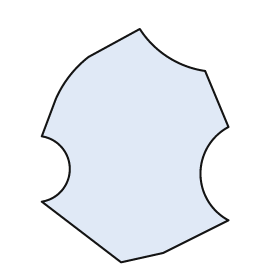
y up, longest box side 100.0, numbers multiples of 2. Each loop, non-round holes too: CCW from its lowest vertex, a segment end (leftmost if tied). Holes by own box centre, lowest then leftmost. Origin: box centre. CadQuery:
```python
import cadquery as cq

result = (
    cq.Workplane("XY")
    .moveTo(-6.0, -50.0)
    .lineTo(12.0, -46.0)
    .lineTo(40.0, -32.0)
    .threePointArc((28.0, -12.0), (40.0, 8.0))
    .lineTo(30.0, 32.0)
    .threePointArc((14.0, 38.0), (2.0, 50.0))
    .lineTo(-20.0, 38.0)
    .threePointArc((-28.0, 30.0), (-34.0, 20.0))
    .lineTo(-40.0, 4.0)
    .threePointArc((-28.0, -10.0), (-40.0, -24.0))
    .close()
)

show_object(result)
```